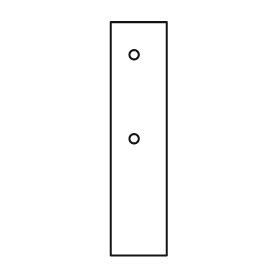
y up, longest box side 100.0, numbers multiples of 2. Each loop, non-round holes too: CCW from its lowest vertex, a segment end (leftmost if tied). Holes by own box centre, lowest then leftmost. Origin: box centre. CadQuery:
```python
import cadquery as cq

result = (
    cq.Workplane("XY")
    .moveTo(-12.0, -50.0)
    .lineTo(12.0, -50.0)
    .lineTo(12.0, 50.0)
    .lineTo(-12.0, 50.0)
    .close()
    .moveTo(-2.0, 0.0)
    .circle(2.0)
    .moveTo(-2.0, 36.0)
    .circle(2.0)
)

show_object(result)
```